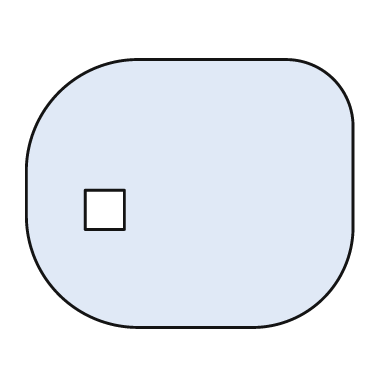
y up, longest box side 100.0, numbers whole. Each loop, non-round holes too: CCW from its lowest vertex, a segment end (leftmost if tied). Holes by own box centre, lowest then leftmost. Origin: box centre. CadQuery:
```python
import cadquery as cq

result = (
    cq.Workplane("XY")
    .moveTo(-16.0, -41.0)
    .lineTo(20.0, -41.0)
    .threePointArc((41.0, -32.0), (50.0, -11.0))
    .lineTo(50.0, 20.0)
    .threePointArc((44.0, 35.0), (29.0, 41.0))
    .lineTo(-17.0, 41.0)
    .threePointArc((-40.0, 31.0), (-50.0, 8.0))
    .lineTo(-50.0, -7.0)
    .threePointArc((-40.0, -31.0), (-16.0, -41.0))
    .close()
    .moveTo(-32.0, -11.0)
    .lineTo(-20.0, -11.0)
    .lineTo(-20.0, 1.0)
    .lineTo(-32.0, 1.0)
    .close()
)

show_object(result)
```